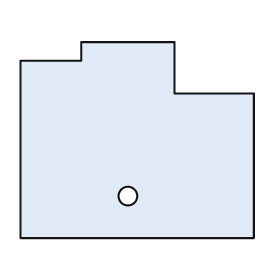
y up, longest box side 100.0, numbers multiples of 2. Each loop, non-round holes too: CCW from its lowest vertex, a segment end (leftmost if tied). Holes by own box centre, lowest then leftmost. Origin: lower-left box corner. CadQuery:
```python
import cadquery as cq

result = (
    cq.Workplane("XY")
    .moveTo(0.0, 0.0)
    .lineTo(100.0, 0.0)
    .lineTo(100.0, 62.0)
    .lineTo(66.0, 62.0)
    .lineTo(66.0, 84.0)
    .lineTo(26.0, 84.0)
    .lineTo(26.0, 76.0)
    .lineTo(0.0, 76.0)
    .close()
    .moveTo(46.0, 18.0)
    .circle(4.0)
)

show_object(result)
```